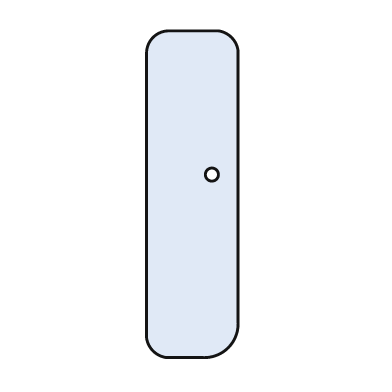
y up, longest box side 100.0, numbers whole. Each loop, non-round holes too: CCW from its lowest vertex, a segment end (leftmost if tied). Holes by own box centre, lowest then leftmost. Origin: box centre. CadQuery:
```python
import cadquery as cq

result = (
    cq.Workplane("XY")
    .moveTo(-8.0, -50.0)
    .lineTo(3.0, -50.0)
    .threePointArc((11.0, -47.0), (14.0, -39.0))
    .lineTo(14.0, 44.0)
    .threePointArc((12.0, 48.0), (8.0, 50.0))
    .lineTo(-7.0, 50.0)
    .threePointArc((-12.0, 48.0), (-14.0, 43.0))
    .lineTo(-14.0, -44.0)
    .threePointArc((-12.0, -48.0), (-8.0, -50.0))
    .close()
    .moveTo(6.0, 6.0)
    .circle(2.0)
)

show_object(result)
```